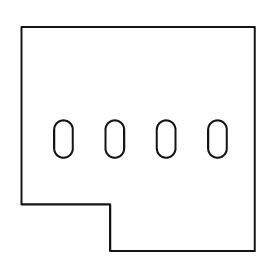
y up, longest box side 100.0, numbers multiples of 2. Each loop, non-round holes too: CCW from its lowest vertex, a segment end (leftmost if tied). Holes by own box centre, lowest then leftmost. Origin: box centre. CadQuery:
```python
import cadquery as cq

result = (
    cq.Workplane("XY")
    .moveTo(-12.0, -48.0)
    .lineTo(50.0, -48.0)
    .lineTo(50.0, 48.0)
    .lineTo(-50.0, 48.0)
    .lineTo(-50.0, -28.0)
    .lineTo(-12.0, -28.0)
    .close()
    .moveTo(-36.0, -4.0)
    .threePointArc((-32.0, -8.0), (-28.0, -4.0))
    .lineTo(-28.0, 4.0)
    .threePointArc((-32.0, 8.0), (-36.0, 4.0))
    .close()
    .moveTo(-14.0, -4.0)
    .threePointArc((-10.0, -8.0), (-6.0, -4.0))
    .lineTo(-6.0, 4.0)
    .threePointArc((-10.0, 8.0), (-14.0, 4.0))
    .close()
    .moveTo(8.0, -4.0)
    .threePointArc((12.0, -8.0), (16.0, -4.0))
    .lineTo(16.0, 4.0)
    .threePointArc((12.0, 8.0), (8.0, 4.0))
    .close()
    .moveTo(30.0, -4.0)
    .threePointArc((34.0, -8.0), (38.0, -4.0))
    .lineTo(38.0, 4.0)
    .threePointArc((34.0, 8.0), (30.0, 4.0))
    .close()
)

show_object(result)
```